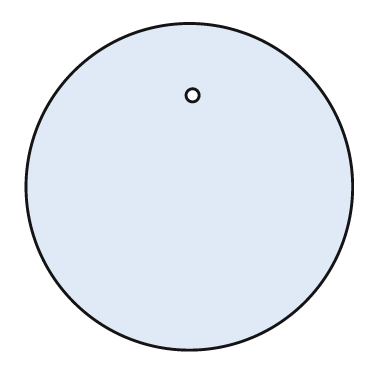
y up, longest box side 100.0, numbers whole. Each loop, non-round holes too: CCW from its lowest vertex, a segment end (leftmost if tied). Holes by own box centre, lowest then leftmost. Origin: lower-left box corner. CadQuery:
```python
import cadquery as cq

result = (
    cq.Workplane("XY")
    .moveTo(50.0, 50.0)
    .circle(50.0)
    .moveTo(51.0, 78.0)
    .circle(2.0)
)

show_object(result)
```